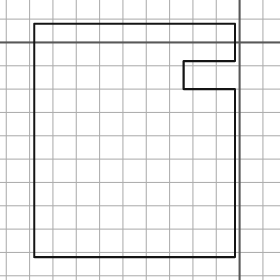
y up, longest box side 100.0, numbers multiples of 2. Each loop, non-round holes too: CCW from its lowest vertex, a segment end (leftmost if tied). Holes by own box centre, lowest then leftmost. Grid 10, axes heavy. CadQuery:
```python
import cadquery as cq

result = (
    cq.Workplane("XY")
    .moveTo(-88.0, -92.0)
    .lineTo(-2.0, -92.0)
    .lineTo(-2.0, -20.0)
    .lineTo(-24.0, -20.0)
    .lineTo(-24.0, -8.0)
    .lineTo(-2.0, -8.0)
    .lineTo(-2.0, 8.0)
    .lineTo(-88.0, 8.0)
    .close()
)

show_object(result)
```